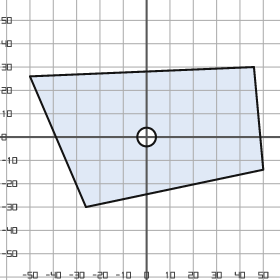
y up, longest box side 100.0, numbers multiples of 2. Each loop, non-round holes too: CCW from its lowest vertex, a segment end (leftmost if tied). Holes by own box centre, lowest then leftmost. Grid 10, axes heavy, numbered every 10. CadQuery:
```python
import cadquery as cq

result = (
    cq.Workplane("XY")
    .moveTo(-26.0, -30.0)
    .lineTo(50.0, -14.0)
    .lineTo(46.0, 30.0)
    .lineTo(-50.0, 26.0)
    .close()
    .moveTo(0.0, 0.0)
    .circle(4.0)
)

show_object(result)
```